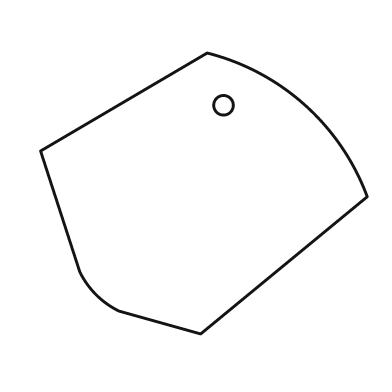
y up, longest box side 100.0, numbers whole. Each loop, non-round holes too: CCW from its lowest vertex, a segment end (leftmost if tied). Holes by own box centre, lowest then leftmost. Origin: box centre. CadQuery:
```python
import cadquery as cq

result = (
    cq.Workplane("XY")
    .moveTo(-1.0, -43.0)
    .lineTo(50.0, -1.0)
    .threePointArc((31.0, 27.0), (1.0, 43.0))
    .lineTo(-50.0, 13.0)
    .lineTo(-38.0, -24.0)
    .threePointArc((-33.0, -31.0), (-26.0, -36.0))
    .close()
    .moveTo(6.0, 27.0)
    .circle(3.0)
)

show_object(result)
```